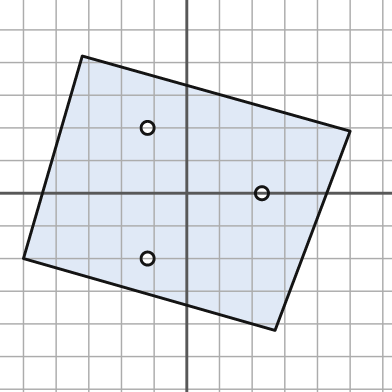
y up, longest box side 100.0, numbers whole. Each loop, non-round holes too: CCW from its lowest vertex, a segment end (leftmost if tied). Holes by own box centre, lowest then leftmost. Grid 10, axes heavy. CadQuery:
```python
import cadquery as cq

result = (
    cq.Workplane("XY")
    .moveTo(27.0, -42.0)
    .lineTo(50.0, 19.0)
    .lineTo(-32.0, 42.0)
    .lineTo(-50.0, -20.0)
    .close()
    .moveTo(-12.0, -20.0)
    .circle(2.0)
    .moveTo(23.0, 0.0)
    .circle(2.0)
    .moveTo(-12.0, 20.0)
    .circle(2.0)
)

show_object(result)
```